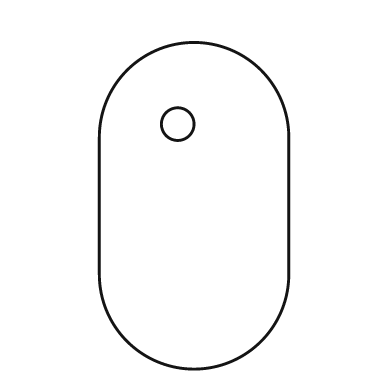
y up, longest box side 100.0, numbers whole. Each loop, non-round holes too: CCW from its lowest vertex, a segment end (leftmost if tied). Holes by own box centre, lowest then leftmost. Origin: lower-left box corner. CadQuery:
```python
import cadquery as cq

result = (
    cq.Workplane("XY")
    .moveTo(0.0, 29.0)
    .threePointArc((29.0, 0.0), (58.0, 29.0))
    .lineTo(58.0, 71.0)
    .threePointArc((29.0, 100.0), (0.0, 71.0))
    .close()
    .moveTo(24.0, 75.0)
    .circle(5.0)
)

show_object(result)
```